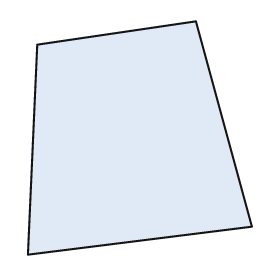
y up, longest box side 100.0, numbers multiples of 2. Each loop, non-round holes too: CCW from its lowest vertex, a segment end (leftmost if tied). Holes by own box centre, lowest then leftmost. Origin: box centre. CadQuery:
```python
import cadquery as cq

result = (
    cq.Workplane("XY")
    .moveTo(-48.0, -50.0)
    .lineTo(48.0, -38.0)
    .lineTo(24.0, 50.0)
    .lineTo(-44.0, 40.0)
    .close()
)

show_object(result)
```